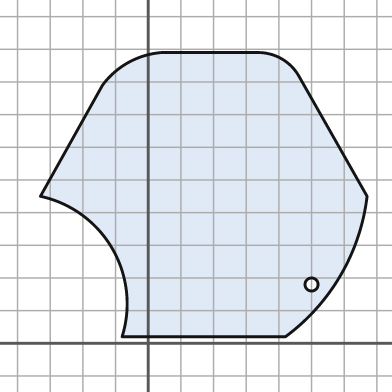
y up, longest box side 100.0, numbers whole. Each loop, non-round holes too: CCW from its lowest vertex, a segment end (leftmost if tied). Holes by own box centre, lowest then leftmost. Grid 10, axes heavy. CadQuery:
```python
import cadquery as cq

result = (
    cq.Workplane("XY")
    .moveTo(-8.0, 2.0)
    .lineTo(42.0, 2.0)
    .threePointArc((59.0, 21.0), (67.0, 45.0))
    .lineTo(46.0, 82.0)
    .threePointArc((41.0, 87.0), (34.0, 89.0))
    .lineTo(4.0, 89.0)
    .threePointArc((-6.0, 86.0), (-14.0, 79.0))
    .lineTo(-33.0, 45.0)
    .threePointArc((-11.0, 29.0), (-8.0, 2.0))
    .close()
    .moveTo(50.0, 18.0)
    .circle(2.0)
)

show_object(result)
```